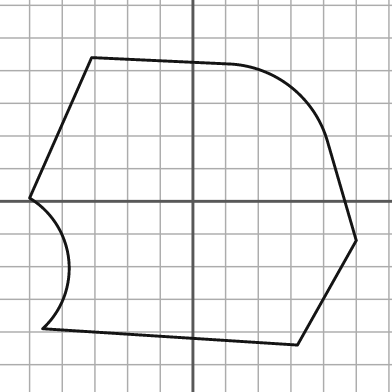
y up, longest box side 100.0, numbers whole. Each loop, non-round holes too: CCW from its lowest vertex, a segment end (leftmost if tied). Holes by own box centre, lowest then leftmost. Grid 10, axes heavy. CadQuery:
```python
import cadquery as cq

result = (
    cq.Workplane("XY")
    .moveTo(32.0, -44.0)
    .lineTo(50.0, -12.0)
    .lineTo(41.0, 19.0)
    .threePointArc((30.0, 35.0), (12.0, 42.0))
    .lineTo(-31.0, 44.0)
    .lineTo(-50.0, 1.0)
    .threePointArc((-38.0, -18.0), (-46.0, -39.0))
    .close()
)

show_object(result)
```